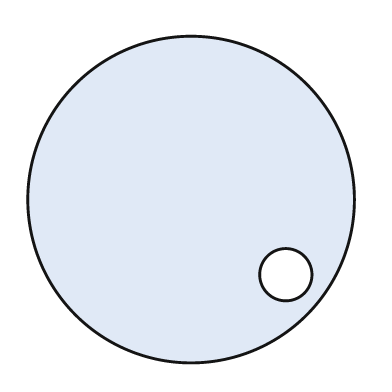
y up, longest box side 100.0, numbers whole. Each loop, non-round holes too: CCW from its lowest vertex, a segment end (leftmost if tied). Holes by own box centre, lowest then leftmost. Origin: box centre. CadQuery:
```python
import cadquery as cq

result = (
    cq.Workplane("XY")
    .moveTo(0.0, 0.0)
    .circle(50.0)
    .moveTo(29.0, -23.0)
    .circle(8.0)
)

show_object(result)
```